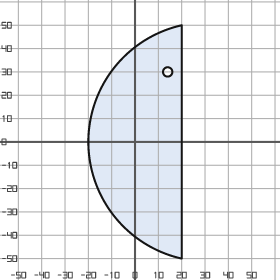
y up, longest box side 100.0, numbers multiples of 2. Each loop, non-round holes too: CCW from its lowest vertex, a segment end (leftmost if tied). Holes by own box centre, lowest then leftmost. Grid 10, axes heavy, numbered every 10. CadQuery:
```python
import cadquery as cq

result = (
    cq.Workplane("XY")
    .moveTo(20.0, -50.0)
    .lineTo(20.0, 50.0)
    .threePointArc((-20.0, 0.0), (20.0, -50.0))
    .close()
    .moveTo(14.0, 30.0)
    .circle(2.0)
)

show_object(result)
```